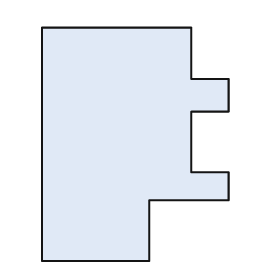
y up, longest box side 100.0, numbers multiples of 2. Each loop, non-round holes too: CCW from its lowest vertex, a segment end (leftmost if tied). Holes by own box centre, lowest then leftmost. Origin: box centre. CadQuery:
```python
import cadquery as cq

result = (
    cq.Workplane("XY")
    .moveTo(-40.0, -50.0)
    .lineTo(6.0, -50.0)
    .lineTo(6.0, -24.0)
    .lineTo(40.0, -24.0)
    .lineTo(40.0, -12.0)
    .lineTo(24.0, -12.0)
    .lineTo(24.0, 14.0)
    .lineTo(40.0, 14.0)
    .lineTo(40.0, 28.0)
    .lineTo(24.0, 28.0)
    .lineTo(24.0, 50.0)
    .lineTo(-40.0, 50.0)
    .close()
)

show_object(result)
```